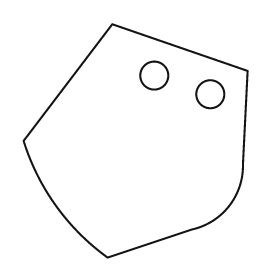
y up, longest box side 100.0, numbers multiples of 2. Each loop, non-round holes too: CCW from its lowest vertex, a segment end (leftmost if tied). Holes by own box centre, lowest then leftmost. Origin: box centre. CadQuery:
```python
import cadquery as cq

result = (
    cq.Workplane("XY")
    .moveTo(-12.0, -50.0)
    .lineTo(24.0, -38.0)
    .threePointArc((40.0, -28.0), (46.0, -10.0))
    .lineTo(48.0, 30.0)
    .lineTo(-10.0, 50.0)
    .lineTo(-48.0, 0.0)
    .threePointArc((-34.0, -28.0), (-12.0, -50.0))
    .close()
    .moveTo(32.0, 20.0)
    .circle(6.0)
    .moveTo(8.0, 28.0)
    .circle(6.0)
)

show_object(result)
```